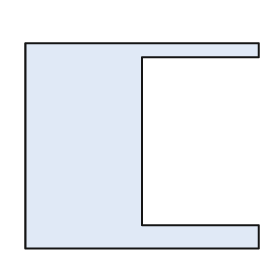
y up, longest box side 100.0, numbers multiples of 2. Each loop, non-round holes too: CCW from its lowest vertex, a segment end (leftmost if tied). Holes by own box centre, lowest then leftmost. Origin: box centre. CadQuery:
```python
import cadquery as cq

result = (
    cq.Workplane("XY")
    .moveTo(-50.0, -44.0)
    .lineTo(50.0, -44.0)
    .lineTo(50.0, -34.0)
    .lineTo(0.0, -34.0)
    .lineTo(0.0, 38.0)
    .lineTo(50.0, 38.0)
    .lineTo(50.0, 44.0)
    .lineTo(-50.0, 44.0)
    .close()
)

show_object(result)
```